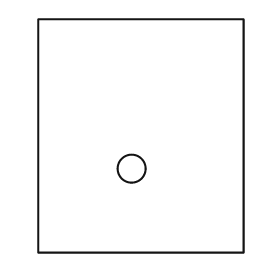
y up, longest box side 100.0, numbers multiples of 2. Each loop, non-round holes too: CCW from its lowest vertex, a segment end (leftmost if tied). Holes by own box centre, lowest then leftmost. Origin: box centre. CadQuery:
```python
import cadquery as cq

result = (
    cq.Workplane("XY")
    .moveTo(-44.0, -50.0)
    .lineTo(44.0, -50.0)
    .lineTo(44.0, 50.0)
    .lineTo(-44.0, 50.0)
    .close()
    .moveTo(-4.0, -14.0)
    .circle(6.0)
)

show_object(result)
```